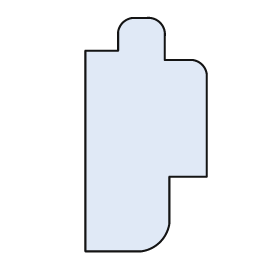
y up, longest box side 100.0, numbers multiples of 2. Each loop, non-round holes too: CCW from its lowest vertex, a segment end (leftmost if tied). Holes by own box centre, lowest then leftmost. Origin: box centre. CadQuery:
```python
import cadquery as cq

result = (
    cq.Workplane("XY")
    .moveTo(-26.0, -50.0)
    .lineTo(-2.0, -50.0)
    .threePointArc((6.0, -46.0), (10.0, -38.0))
    .lineTo(10.0, -18.0)
    .lineTo(26.0, -18.0)
    .lineTo(26.0, 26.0)
    .threePointArc((24.0, 30.0), (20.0, 32.0))
    .lineTo(8.0, 32.0)
    .lineTo(8.0, 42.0)
    .threePointArc((6.0, 48.0), (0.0, 50.0))
    .lineTo(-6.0, 50.0)
    .threePointArc((-10.0, 48.0), (-12.0, 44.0))
    .lineTo(-12.0, 36.0)
    .lineTo(-26.0, 36.0)
    .close()
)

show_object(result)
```